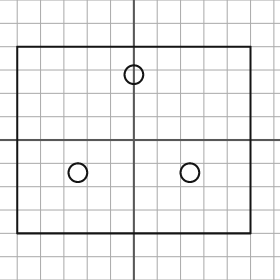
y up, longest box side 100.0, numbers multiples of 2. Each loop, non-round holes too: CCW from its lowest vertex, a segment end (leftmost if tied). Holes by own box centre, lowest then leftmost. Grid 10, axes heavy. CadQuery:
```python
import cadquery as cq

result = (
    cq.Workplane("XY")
    .moveTo(-50.0, -40.0)
    .lineTo(50.0, -40.0)
    .lineTo(50.0, 40.0)
    .lineTo(-50.0, 40.0)
    .close()
    .moveTo(-24.0, -14.0)
    .circle(4.0)
    .moveTo(24.0, -14.0)
    .circle(4.0)
    .moveTo(0.0, 28.0)
    .circle(4.0)
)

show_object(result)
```